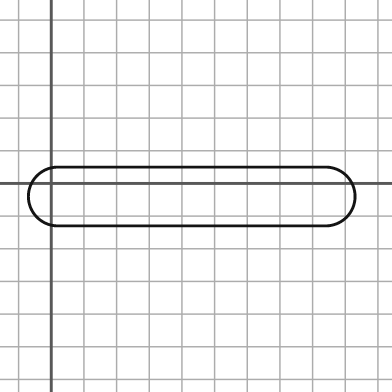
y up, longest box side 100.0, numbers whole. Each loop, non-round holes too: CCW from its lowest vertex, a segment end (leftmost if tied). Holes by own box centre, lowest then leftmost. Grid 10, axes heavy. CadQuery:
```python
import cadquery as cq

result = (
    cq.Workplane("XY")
    .moveTo(2.0, -13.0)
    .lineTo(84.0, -13.0)
    .threePointArc((93.0, -4.0), (84.0, 5.0))
    .lineTo(2.0, 5.0)
    .threePointArc((-7.0, -4.0), (2.0, -13.0))
    .close()
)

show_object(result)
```